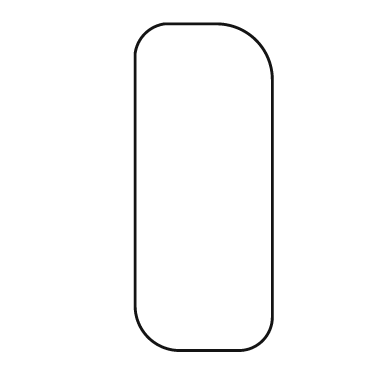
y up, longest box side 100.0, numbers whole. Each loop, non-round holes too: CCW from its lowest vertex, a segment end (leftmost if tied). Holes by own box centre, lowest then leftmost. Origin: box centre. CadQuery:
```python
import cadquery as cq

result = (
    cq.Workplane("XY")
    .moveTo(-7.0, -50.0)
    .lineTo(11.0, -50.0)
    .threePointArc((18.0, -47.0), (21.0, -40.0))
    .lineTo(21.0, 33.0)
    .threePointArc((16.0, 45.0), (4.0, 50.0))
    .lineTo(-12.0, 50.0)
    .threePointArc((-18.0, 47.0), (-21.0, 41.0))
    .lineTo(-21.0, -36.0)
    .threePointArc((-17.0, -46.0), (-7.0, -50.0))
    .close()
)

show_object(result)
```